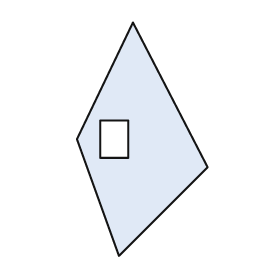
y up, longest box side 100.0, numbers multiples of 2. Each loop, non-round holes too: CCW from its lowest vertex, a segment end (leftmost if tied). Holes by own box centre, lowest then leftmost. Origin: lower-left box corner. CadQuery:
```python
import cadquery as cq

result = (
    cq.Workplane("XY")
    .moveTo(18.0, 0.0)
    .lineTo(56.0, 38.0)
    .lineTo(24.0, 100.0)
    .lineTo(0.0, 50.0)
    .close()
    .moveTo(10.0, 42.0)
    .lineTo(22.0, 42.0)
    .lineTo(22.0, 58.0)
    .lineTo(10.0, 58.0)
    .close()
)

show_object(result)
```